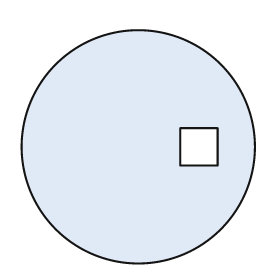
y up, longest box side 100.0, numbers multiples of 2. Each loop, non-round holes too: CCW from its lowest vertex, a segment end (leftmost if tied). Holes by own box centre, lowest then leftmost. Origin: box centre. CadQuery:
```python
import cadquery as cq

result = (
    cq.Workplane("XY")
    .moveTo(0.0, 0.0)
    .circle(50.0)
    .moveTo(18.0, -8.0)
    .lineTo(34.0, -8.0)
    .lineTo(34.0, 8.0)
    .lineTo(18.0, 8.0)
    .close()
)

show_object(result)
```